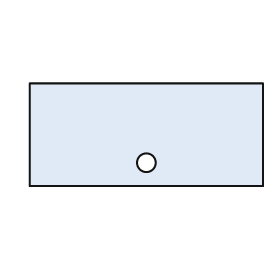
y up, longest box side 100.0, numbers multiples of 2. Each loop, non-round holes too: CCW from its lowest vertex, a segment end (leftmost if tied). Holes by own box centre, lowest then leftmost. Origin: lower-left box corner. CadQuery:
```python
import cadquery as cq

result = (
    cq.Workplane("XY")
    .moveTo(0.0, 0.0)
    .lineTo(100.0, 0.0)
    .lineTo(100.0, 44.0)
    .lineTo(0.0, 44.0)
    .close()
    .moveTo(50.0, 10.0)
    .circle(4.0)
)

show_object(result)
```